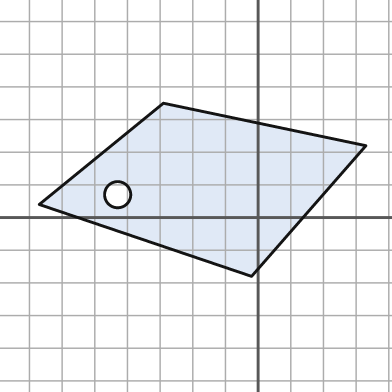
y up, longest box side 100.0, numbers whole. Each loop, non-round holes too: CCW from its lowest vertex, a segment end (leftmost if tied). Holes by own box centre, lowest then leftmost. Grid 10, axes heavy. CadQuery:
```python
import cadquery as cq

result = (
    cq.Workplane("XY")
    .moveTo(-2.0, -18.0)
    .lineTo(33.0, 22.0)
    .lineTo(-29.0, 35.0)
    .lineTo(-67.0, 4.0)
    .close()
    .moveTo(-43.0, 7.0)
    .circle(4.0)
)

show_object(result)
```